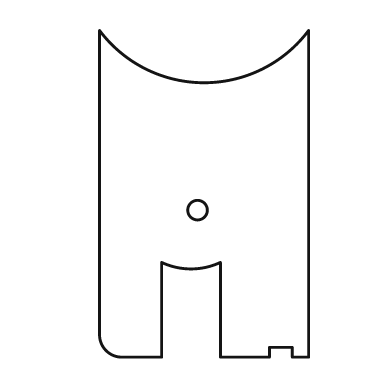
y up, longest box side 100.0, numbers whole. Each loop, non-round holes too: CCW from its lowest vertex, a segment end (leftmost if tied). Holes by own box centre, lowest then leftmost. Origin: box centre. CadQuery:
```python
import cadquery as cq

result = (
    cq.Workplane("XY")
    .moveTo(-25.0, -50.0)
    .lineTo(-13.0, -50.0)
    .lineTo(-13.0, -21.0)
    .threePointArc((-4.0, -23.0), (5.0, -21.0))
    .lineTo(5.0, -50.0)
    .lineTo(20.0, -50.0)
    .lineTo(20.0, -47.0)
    .lineTo(27.0, -47.0)
    .lineTo(27.0, -50.0)
    .lineTo(32.0, -50.0)
    .lineTo(32.0, 50.0)
    .threePointArc((0.0, 34.0), (-32.0, 50.0))
    .lineTo(-32.0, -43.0)
    .threePointArc((-30.0, -48.0), (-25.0, -50.0))
    .close()
    .moveTo(-2.0, -5.0)
    .circle(3.0)
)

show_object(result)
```